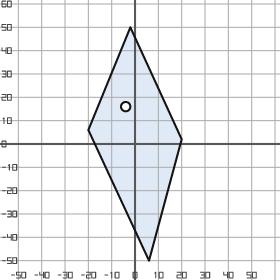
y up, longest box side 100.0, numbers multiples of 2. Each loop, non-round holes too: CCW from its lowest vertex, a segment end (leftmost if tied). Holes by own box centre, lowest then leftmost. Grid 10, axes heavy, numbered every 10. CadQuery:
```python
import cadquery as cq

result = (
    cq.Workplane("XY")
    .moveTo(6.0, -50.0)
    .lineTo(20.0, 2.0)
    .lineTo(-2.0, 50.0)
    .lineTo(-20.0, 6.0)
    .close()
    .moveTo(-4.0, 16.0)
    .circle(2.0)
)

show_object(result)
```